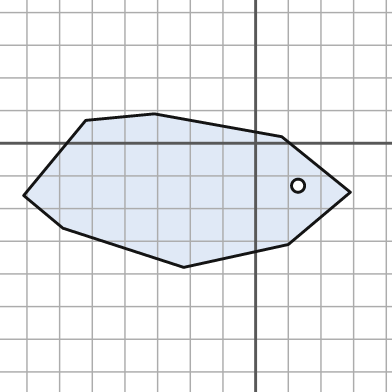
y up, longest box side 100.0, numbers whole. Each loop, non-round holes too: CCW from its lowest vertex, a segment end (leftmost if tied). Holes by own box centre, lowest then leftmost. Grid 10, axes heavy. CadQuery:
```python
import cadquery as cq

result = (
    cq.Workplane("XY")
    .moveTo(-22.0, -38.0)
    .lineTo(10.0, -31.0)
    .lineTo(29.0, -15.0)
    .lineTo(8.0, 2.0)
    .lineTo(-31.0, 9.0)
    .lineTo(-52.0, 7.0)
    .lineTo(-71.0, -16.0)
    .lineTo(-59.0, -26.0)
    .close()
    .moveTo(13.0, -13.0)
    .circle(2.0)
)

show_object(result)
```